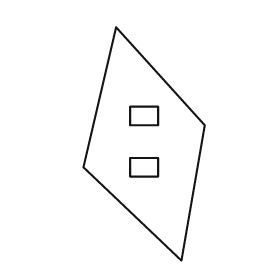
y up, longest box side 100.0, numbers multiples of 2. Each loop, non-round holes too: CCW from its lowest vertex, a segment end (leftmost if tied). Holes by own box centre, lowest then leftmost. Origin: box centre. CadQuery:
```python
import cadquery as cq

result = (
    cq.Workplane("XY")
    .moveTo(16.0, -50.0)
    .lineTo(26.0, 8.0)
    .lineTo(-12.0, 50.0)
    .lineTo(-26.0, -10.0)
    .close()
    .moveTo(-6.0, -14.0)
    .lineTo(6.0, -14.0)
    .lineTo(6.0, -6.0)
    .lineTo(-6.0, -6.0)
    .close()
    .moveTo(-6.0, 8.0)
    .lineTo(6.0, 8.0)
    .lineTo(6.0, 16.0)
    .lineTo(-6.0, 16.0)
    .close()
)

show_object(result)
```